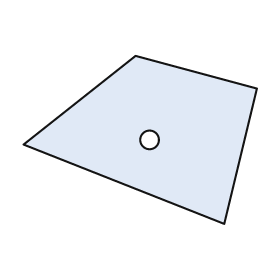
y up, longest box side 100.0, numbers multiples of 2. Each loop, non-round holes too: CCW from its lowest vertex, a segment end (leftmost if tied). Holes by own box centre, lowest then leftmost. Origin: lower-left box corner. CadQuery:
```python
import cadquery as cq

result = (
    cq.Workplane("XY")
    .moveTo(86.0, 0.0)
    .lineTo(100.0, 58.0)
    .lineTo(48.0, 72.0)
    .lineTo(0.0, 34.0)
    .close()
    .moveTo(54.0, 36.0)
    .circle(4.0)
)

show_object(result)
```